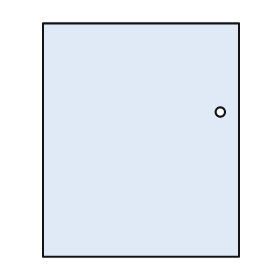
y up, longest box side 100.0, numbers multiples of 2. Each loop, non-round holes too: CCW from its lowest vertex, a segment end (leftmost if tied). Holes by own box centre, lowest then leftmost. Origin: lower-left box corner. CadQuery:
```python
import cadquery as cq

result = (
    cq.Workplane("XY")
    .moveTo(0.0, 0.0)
    .lineTo(84.0, 0.0)
    .lineTo(84.0, 100.0)
    .lineTo(0.0, 100.0)
    .close()
    .moveTo(76.0, 62.0)
    .circle(2.0)
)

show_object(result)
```